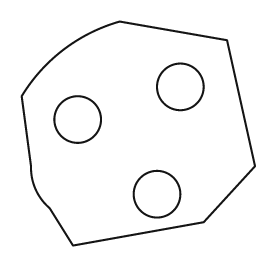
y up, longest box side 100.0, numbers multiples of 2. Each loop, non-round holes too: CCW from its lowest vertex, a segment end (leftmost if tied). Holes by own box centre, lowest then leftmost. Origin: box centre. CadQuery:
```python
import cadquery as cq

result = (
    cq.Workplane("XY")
    .moveTo(-28.0, -48.0)
    .lineTo(28.0, -38.0)
    .lineTo(50.0, -14.0)
    .lineTo(38.0, 40.0)
    .lineTo(-8.0, 48.0)
    .threePointArc((-32.0, 36.0), (-50.0, 16.0))
    .lineTo(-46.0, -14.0)
    .threePointArc((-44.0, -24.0), (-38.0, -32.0))
    .close()
    .moveTo(8.0, -26.0)
    .circle(10.0)
    .moveTo(-26.0, 6.0)
    .circle(10.0)
    .moveTo(18.0, 20.0)
    .circle(10.0)
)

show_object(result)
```